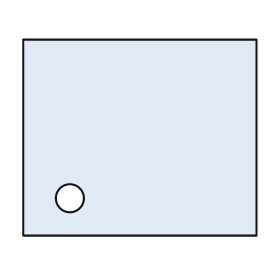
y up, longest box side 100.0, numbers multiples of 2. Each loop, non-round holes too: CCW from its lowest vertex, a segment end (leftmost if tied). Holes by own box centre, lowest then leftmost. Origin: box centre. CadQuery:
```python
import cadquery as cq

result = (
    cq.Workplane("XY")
    .moveTo(-50.0, -42.0)
    .lineTo(50.0, -42.0)
    .lineTo(50.0, 42.0)
    .lineTo(-50.0, 42.0)
    .close()
    .moveTo(-30.0, -26.0)
    .circle(6.0)
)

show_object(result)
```